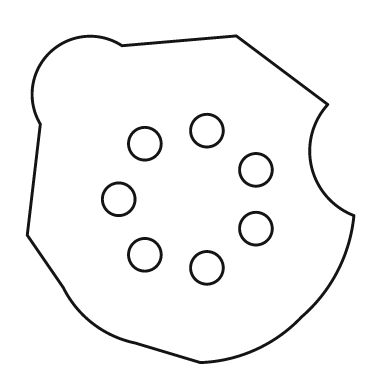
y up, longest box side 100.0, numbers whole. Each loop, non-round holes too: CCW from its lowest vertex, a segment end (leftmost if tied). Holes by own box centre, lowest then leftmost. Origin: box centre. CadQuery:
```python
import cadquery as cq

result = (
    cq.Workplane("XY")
    .moveTo(3.0, -50.0)
    .threePointArc((20.0, -46.0), (34.0, -36.0))
    .threePointArc((45.0, -22.0), (50.0, -5.0))
    .threePointArc((37.0, 10.0), (42.0, 29.0))
    .lineTo(14.0, 50.0)
    .lineTo(-21.0, 47.0)
    .threePointArc((-43.0, 45.0), (-46.0, 23.0))
    .lineTo(-50.0, -11.0)
    .lineTo(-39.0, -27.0)
    .threePointArc((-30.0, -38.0), (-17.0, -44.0))
    .close()
    .moveTo(5.0, -21.0)
    .circle(5.0)
    .moveTo(-14.0, -17.0)
    .circle(5.0)
    .moveTo(20.0, -9.0)
    .circle(5.0)
    .moveTo(-22.0, 0.0)
    .circle(5.0)
    .moveTo(20.0, 9.0)
    .circle(5.0)
    .moveTo(-14.0, 17.0)
    .circle(5.0)
    .moveTo(5.0, 21.0)
    .circle(5.0)
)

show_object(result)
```